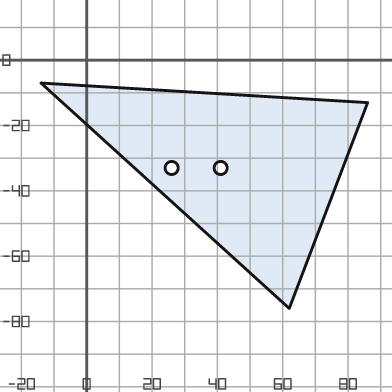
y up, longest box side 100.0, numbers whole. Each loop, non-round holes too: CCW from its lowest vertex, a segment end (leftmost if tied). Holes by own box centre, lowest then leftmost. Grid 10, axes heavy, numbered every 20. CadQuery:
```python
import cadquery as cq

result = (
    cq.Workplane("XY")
    .moveTo(62.0, -76.0)
    .lineTo(86.0, -13.0)
    .lineTo(-14.0, -7.0)
    .close()
    .moveTo(26.0, -33.0)
    .circle(2.0)
    .moveTo(41.0, -33.0)
    .circle(2.0)
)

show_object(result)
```